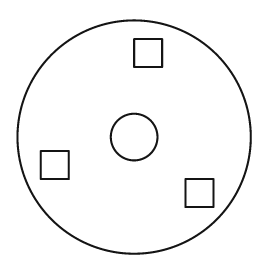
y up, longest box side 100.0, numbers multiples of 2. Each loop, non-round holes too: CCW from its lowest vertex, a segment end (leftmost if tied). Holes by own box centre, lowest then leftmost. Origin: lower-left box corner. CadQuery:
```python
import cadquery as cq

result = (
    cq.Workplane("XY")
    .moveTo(50.0, 50.0)
    .circle(50.0)
    .moveTo(72.0, 20.0)
    .lineTo(84.0, 20.0)
    .lineTo(84.0, 32.0)
    .lineTo(72.0, 32.0)
    .close()
    .moveTo(10.0, 32.0)
    .lineTo(22.0, 32.0)
    .lineTo(22.0, 44.0)
    .lineTo(10.0, 44.0)
    .close()
    .moveTo(50.0, 50.0)
    .circle(10.0)
    .moveTo(50.0, 80.0)
    .lineTo(62.0, 80.0)
    .lineTo(62.0, 92.0)
    .lineTo(50.0, 92.0)
    .close()
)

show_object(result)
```